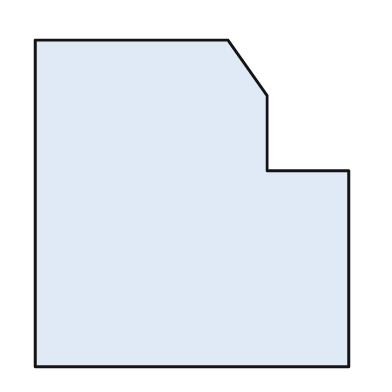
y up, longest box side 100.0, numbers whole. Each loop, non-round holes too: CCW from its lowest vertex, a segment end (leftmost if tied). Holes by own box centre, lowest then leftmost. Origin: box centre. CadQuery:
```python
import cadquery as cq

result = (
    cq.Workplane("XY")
    .moveTo(-48.0, -50.0)
    .lineTo(48.0, -50.0)
    .lineTo(48.0, 10.0)
    .lineTo(23.0, 10.0)
    .lineTo(23.0, 33.0)
    .lineTo(11.0, 50.0)
    .lineTo(-48.0, 50.0)
    .close()
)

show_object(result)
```